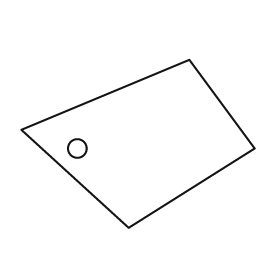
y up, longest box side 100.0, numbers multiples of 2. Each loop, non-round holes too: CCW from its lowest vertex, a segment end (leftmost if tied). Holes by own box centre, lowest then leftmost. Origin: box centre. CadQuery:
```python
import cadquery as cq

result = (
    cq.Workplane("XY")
    .moveTo(-4.0, -36.0)
    .lineTo(50.0, -2.0)
    .lineTo(22.0, 36.0)
    .lineTo(-50.0, 6.0)
    .close()
    .moveTo(-26.0, -2.0)
    .circle(4.0)
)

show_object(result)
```